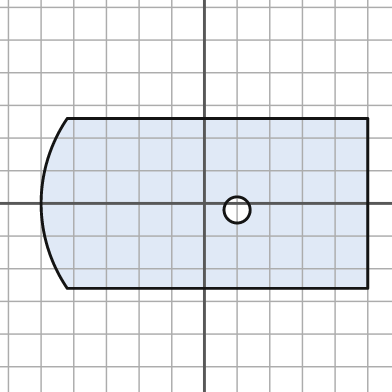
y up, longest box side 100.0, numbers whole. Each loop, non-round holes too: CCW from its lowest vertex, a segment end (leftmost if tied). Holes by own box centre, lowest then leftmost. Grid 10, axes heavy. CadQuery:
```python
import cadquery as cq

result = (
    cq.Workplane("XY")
    .moveTo(-42.0, -26.0)
    .lineTo(50.0, -26.0)
    .lineTo(50.0, 26.0)
    .lineTo(-42.0, 26.0)
    .threePointArc((-50.0, 0.0), (-42.0, -26.0))
    .close()
    .moveTo(10.0, -2.0)
    .circle(4.0)
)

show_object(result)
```